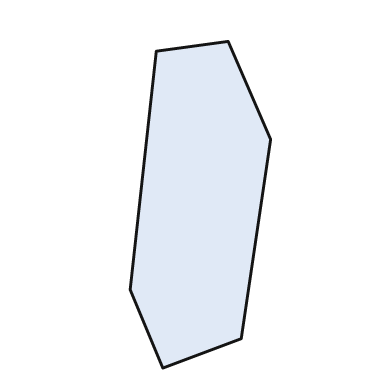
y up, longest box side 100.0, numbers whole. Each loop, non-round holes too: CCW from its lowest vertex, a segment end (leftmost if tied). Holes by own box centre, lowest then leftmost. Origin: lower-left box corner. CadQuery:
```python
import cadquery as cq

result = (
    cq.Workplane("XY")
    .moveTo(10.0, 0.0)
    .lineTo(34.0, 9.0)
    .lineTo(43.0, 70.0)
    .lineTo(30.0, 100.0)
    .lineTo(8.0, 97.0)
    .lineTo(0.0, 24.0)
    .close()
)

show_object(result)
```